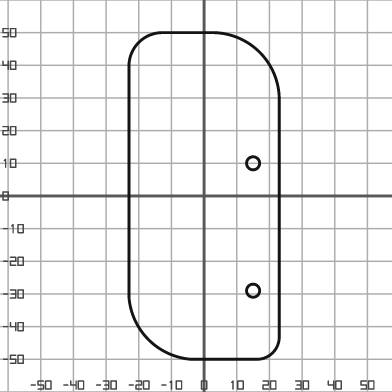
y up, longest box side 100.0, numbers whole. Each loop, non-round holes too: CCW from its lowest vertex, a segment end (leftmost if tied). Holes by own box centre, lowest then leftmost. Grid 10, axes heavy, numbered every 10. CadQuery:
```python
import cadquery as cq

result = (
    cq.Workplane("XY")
    .moveTo(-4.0, -50.0)
    .lineTo(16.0, -50.0)
    .threePointArc((21.0, -48.0), (23.0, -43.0))
    .lineTo(23.0, 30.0)
    .threePointArc((17.0, 44.0), (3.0, 50.0))
    .lineTo(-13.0, 50.0)
    .threePointArc((-20.0, 47.0), (-23.0, 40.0))
    .lineTo(-23.0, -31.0)
    .threePointArc((-17.0, -44.0), (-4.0, -50.0))
    .close()
    .moveTo(15.0, -29.0)
    .circle(2.0)
    .moveTo(15.0, 10.0)
    .circle(2.0)
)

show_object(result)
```